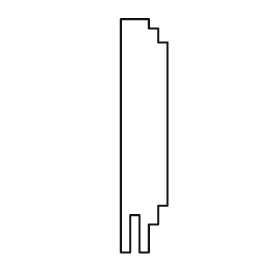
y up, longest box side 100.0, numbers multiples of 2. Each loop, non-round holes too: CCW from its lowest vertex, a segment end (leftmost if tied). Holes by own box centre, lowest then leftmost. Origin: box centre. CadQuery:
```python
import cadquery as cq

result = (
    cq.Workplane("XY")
    .moveTo(-10.0, -50.0)
    .lineTo(-6.0, -50.0)
    .lineTo(-6.0, -34.0)
    .lineTo(-2.0, -34.0)
    .lineTo(-2.0, -50.0)
    .lineTo(2.0, -50.0)
    .lineTo(2.0, -38.0)
    .lineTo(6.0, -38.0)
    .lineTo(6.0, -30.0)
    .lineTo(10.0, -30.0)
    .lineTo(10.0, 40.0)
    .lineTo(6.0, 40.0)
    .lineTo(6.0, 46.0)
    .lineTo(2.0, 46.0)
    .lineTo(2.0, 50.0)
    .lineTo(-10.0, 50.0)
    .close()
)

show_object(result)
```